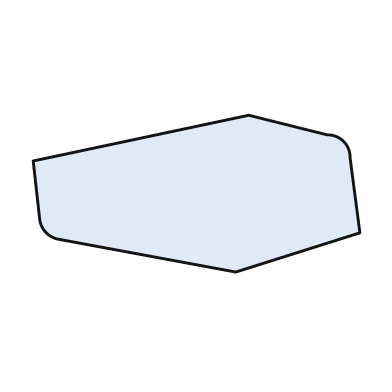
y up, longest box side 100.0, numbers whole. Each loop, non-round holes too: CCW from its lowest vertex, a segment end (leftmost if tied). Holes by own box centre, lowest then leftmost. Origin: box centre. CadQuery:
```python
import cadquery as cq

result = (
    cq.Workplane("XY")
    .moveTo(12.0, -24.0)
    .lineTo(50.0, -12.0)
    .lineTo(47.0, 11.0)
    .threePointArc((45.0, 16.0), (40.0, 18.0))
    .lineTo(16.0, 24.0)
    .lineTo(-50.0, 10.0)
    .lineTo(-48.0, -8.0)
    .threePointArc((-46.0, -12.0), (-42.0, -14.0))
    .close()
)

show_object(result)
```